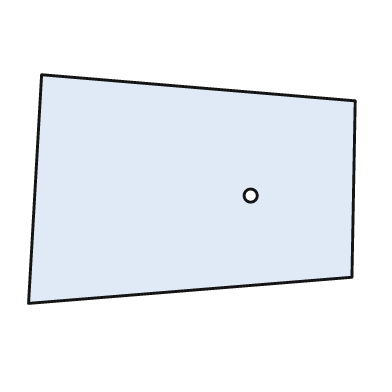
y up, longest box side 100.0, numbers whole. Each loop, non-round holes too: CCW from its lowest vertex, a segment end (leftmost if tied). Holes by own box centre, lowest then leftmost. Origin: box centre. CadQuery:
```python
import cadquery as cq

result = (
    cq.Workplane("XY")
    .moveTo(-50.0, -35.0)
    .lineTo(49.0, -27.0)
    .lineTo(50.0, 27.0)
    .lineTo(-46.0, 35.0)
    .close()
    .moveTo(18.0, -2.0)
    .circle(2.0)
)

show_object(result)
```